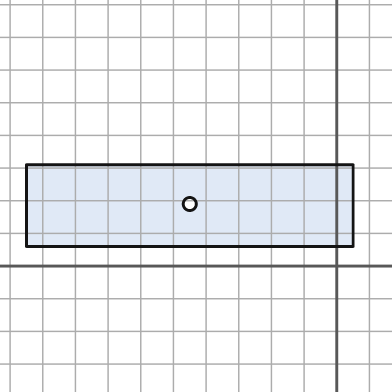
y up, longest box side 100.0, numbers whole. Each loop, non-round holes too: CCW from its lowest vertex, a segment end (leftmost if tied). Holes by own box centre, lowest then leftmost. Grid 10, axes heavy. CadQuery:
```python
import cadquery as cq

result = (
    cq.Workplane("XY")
    .moveTo(-95.0, 6.0)
    .lineTo(5.0, 6.0)
    .lineTo(5.0, 31.0)
    .lineTo(-95.0, 31.0)
    .close()
    .moveTo(-45.0, 19.0)
    .circle(2.0)
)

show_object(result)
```